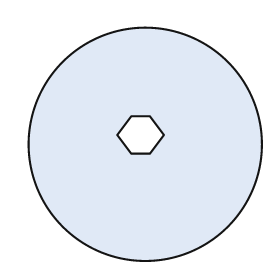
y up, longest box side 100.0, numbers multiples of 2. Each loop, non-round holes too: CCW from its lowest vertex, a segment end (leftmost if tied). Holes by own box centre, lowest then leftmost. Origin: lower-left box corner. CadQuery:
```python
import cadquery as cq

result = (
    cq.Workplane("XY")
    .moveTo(50.0, 50.0)
    .circle(50.0)
    .moveTo(44.0, 46.0)
    .lineTo(52.0, 46.0)
    .lineTo(58.0, 54.0)
    .lineTo(52.0, 62.0)
    .lineTo(44.0, 62.0)
    .lineTo(38.0, 54.0)
    .close()
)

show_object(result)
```